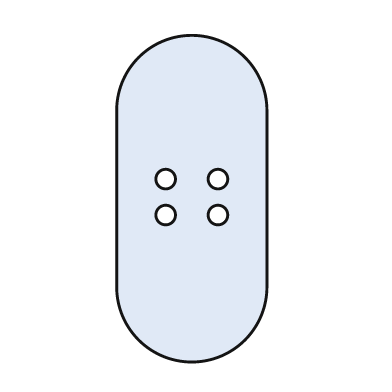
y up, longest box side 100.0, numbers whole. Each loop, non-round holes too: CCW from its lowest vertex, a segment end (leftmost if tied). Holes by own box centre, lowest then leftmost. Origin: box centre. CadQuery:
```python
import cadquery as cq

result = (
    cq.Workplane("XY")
    .moveTo(-23.0, -27.0)
    .threePointArc((0.0, -50.0), (23.0, -27.0))
    .lineTo(23.0, 27.0)
    .threePointArc((0.0, 50.0), (-23.0, 27.0))
    .close()
    .moveTo(-8.0, -5.0)
    .circle(3.0)
    .moveTo(8.0, -5.0)
    .circle(3.0)
    .moveTo(-8.0, 6.0)
    .circle(3.0)
    .moveTo(8.0, 6.0)
    .circle(3.0)
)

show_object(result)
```